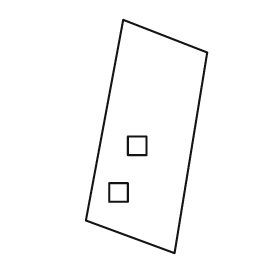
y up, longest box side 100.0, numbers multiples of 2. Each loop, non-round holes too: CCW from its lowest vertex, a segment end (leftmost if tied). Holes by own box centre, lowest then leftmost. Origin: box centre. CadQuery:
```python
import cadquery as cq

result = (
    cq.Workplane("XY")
    .moveTo(12.0, -50.0)
    .lineTo(26.0, 36.0)
    .lineTo(-10.0, 50.0)
    .lineTo(-26.0, -36.0)
    .close()
    .moveTo(-16.0, -28.0)
    .lineTo(-8.0, -28.0)
    .lineTo(-8.0, -20.0)
    .lineTo(-16.0, -20.0)
    .close()
    .moveTo(-8.0, -8.0)
    .lineTo(0.0, -8.0)
    .lineTo(0.0, 0.0)
    .lineTo(-8.0, 0.0)
    .close()
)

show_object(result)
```